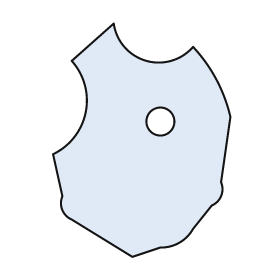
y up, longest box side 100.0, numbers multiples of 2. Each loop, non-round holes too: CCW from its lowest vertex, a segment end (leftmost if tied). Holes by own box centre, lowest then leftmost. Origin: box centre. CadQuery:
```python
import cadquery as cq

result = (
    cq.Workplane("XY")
    .moveTo(-4.0, -50.0)
    .lineTo(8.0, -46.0)
    .threePointArc((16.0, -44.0), (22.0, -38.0))
    .lineTo(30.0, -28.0)
    .threePointArc((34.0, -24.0), (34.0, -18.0))
    .lineTo(38.0, 10.0)
    .threePointArc((32.0, 26.0), (22.0, 40.0))
    .threePointArc((2.0, 34.0), (-12.0, 50.0))
    .lineTo(-30.0, 34.0)
    .threePointArc((-24.0, 12.0), (-38.0, -6.0))
    .lineTo(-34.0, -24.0)
    .threePointArc((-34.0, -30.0), (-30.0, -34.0))
    .close()
    .moveTo(8.0, 8.0)
    .circle(6.0)
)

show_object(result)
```